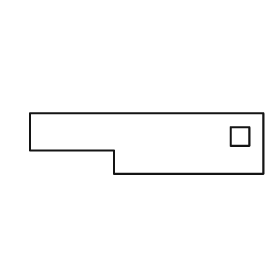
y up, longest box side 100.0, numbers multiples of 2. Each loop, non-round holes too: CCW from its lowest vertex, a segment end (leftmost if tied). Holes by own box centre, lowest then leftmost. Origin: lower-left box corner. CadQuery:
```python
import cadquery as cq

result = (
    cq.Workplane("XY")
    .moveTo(36.0, 0.0)
    .lineTo(100.0, 0.0)
    .lineTo(100.0, 26.0)
    .lineTo(0.0, 26.0)
    .lineTo(0.0, 10.0)
    .lineTo(36.0, 10.0)
    .close()
    .moveTo(86.0, 12.0)
    .lineTo(94.0, 12.0)
    .lineTo(94.0, 20.0)
    .lineTo(86.0, 20.0)
    .close()
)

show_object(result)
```